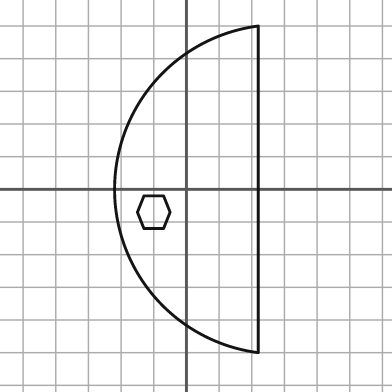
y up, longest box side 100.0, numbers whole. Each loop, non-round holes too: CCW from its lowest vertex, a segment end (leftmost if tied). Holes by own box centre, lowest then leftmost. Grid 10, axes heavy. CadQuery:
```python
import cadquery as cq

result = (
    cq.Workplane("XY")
    .moveTo(22.0, -50.0)
    .lineTo(22.0, 50.0)
    .threePointArc((-22.0, 0.0), (22.0, -50.0))
    .close()
    .moveTo(-13.0, -12.0)
    .lineTo(-7.0, -12.0)
    .lineTo(-5.0, -7.0)
    .lineTo(-7.0, -2.0)
    .lineTo(-13.0, -2.0)
    .lineTo(-15.0, -7.0)
    .close()
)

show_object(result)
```